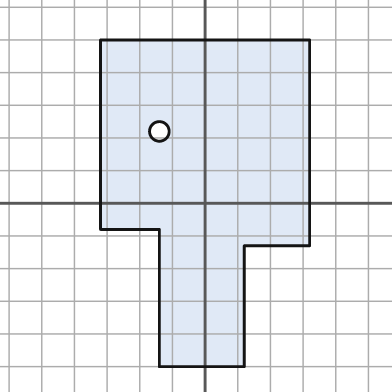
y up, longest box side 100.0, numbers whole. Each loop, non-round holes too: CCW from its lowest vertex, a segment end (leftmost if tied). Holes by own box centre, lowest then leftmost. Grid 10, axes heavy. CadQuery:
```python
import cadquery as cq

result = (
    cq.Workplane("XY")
    .moveTo(-14.0, -50.0)
    .lineTo(12.0, -50.0)
    .lineTo(12.0, -13.0)
    .lineTo(32.0, -13.0)
    .lineTo(32.0, 50.0)
    .lineTo(-32.0, 50.0)
    .lineTo(-32.0, -8.0)
    .lineTo(-14.0, -8.0)
    .close()
    .moveTo(-14.0, 22.0)
    .circle(3.0)
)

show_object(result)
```